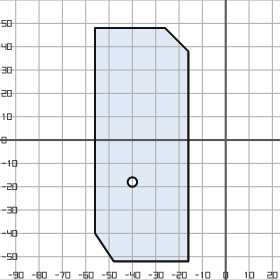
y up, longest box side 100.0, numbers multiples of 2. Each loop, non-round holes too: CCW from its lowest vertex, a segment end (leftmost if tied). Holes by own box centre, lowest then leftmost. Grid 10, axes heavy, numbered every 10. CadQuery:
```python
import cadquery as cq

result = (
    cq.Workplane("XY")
    .moveTo(-48.0, -52.0)
    .lineTo(-16.0, -52.0)
    .lineTo(-16.0, 38.0)
    .lineTo(-26.0, 48.0)
    .lineTo(-56.0, 48.0)
    .lineTo(-56.0, -40.0)
    .close()
    .moveTo(-40.0, -18.0)
    .circle(2.0)
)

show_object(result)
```